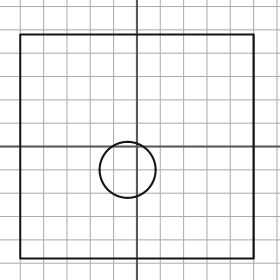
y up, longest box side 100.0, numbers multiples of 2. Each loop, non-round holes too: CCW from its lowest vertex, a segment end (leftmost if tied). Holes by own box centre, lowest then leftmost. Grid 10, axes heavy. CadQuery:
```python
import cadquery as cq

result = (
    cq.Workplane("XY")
    .moveTo(-50.0, -48.0)
    .lineTo(50.0, -48.0)
    .lineTo(50.0, 48.0)
    .lineTo(-50.0, 48.0)
    .close()
    .moveTo(-4.0, -10.0)
    .circle(12.0)
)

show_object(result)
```